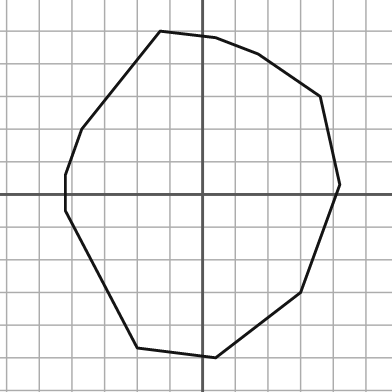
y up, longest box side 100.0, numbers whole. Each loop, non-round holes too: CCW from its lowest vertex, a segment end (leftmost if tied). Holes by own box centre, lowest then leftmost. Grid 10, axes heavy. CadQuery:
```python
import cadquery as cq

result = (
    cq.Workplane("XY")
    .moveTo(4.0, -50.0)
    .lineTo(30.0, -30.0)
    .lineTo(42.0, 3.0)
    .lineTo(36.0, 30.0)
    .lineTo(17.0, 43.0)
    .lineTo(4.0, 48.0)
    .lineTo(-13.0, 50.0)
    .lineTo(-37.0, 20.0)
    .lineTo(-42.0, 6.0)
    .lineTo(-42.0, -5.0)
    .lineTo(-20.0, -47.0)
    .close()
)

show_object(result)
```